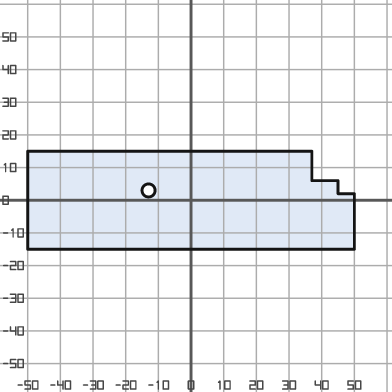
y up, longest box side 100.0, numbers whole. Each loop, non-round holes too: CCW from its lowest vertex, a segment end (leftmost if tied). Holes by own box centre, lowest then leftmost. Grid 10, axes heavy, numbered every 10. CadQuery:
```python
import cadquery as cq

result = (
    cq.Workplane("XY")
    .moveTo(-50.0, -15.0)
    .lineTo(50.0, -15.0)
    .lineTo(50.0, 2.0)
    .lineTo(45.0, 2.0)
    .lineTo(45.0, 6.0)
    .lineTo(37.0, 6.0)
    .lineTo(37.0, 15.0)
    .lineTo(-50.0, 15.0)
    .close()
    .moveTo(-13.0, 3.0)
    .circle(2.0)
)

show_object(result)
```